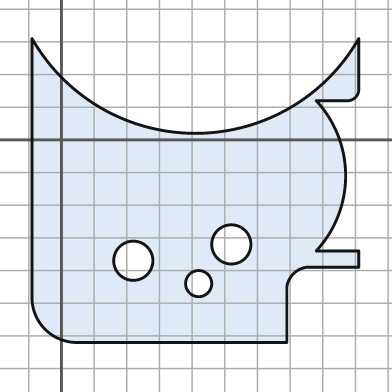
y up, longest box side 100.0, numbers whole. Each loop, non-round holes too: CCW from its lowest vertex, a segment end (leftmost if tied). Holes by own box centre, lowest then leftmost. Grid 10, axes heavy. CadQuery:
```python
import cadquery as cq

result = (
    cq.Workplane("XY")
    .moveTo(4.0, -62.0)
    .lineTo(69.0, -62.0)
    .lineTo(69.0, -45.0)
    .threePointArc((71.0, -41.0), (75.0, -39.0))
    .lineTo(91.0, -39.0)
    .lineTo(91.0, -34.0)
    .lineTo(78.0, -34.0)
    .threePointArc((87.0, -11.0), (78.0, 12.0))
    .lineTo(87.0, 12.0)
    .threePointArc((90.0, 13.0), (91.0, 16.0))
    .lineTo(91.0, 31.0)
    .threePointArc((41.0, 2.0), (-9.0, 31.0))
    .lineTo(-9.0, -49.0)
    .threePointArc((-5.0, -58.0), (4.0, -62.0))
    .close()
    .moveTo(42.0, -44.0)
    .circle(4.0)
    .moveTo(22.0, -37.0)
    .circle(6.0)
    .moveTo(52.0, -32.0)
    .circle(6.0)
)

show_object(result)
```